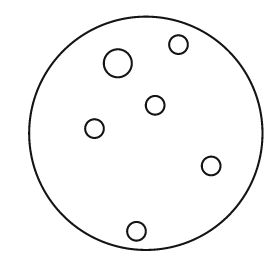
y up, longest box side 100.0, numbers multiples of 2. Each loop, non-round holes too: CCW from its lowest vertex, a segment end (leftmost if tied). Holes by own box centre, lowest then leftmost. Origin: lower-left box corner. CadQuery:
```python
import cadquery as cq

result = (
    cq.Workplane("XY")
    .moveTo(50.0, 50.0)
    .circle(50.0)
    .moveTo(46.0, 8.0)
    .circle(4.0)
    .moveTo(78.0, 36.0)
    .circle(4.0)
    .moveTo(28.0, 52.0)
    .circle(4.0)
    .moveTo(54.0, 62.0)
    .circle(4.0)
    .moveTo(38.0, 80.0)
    .circle(6.0)
    .moveTo(64.0, 88.0)
    .circle(4.0)
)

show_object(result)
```